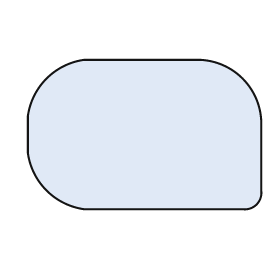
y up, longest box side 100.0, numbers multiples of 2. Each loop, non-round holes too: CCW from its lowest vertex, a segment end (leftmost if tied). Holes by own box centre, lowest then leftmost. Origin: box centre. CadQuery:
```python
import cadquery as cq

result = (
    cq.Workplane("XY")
    .moveTo(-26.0, -32.0)
    .lineTo(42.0, -32.0)
    .threePointArc((48.0, -30.0), (50.0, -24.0))
    .lineTo(50.0, 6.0)
    .threePointArc((42.0, 24.0), (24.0, 32.0))
    .lineTo(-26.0, 32.0)
    .threePointArc((-42.0, 24.0), (-50.0, 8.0))
    .lineTo(-50.0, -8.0)
    .threePointArc((-42.0, -24.0), (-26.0, -32.0))
    .close()
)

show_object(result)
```